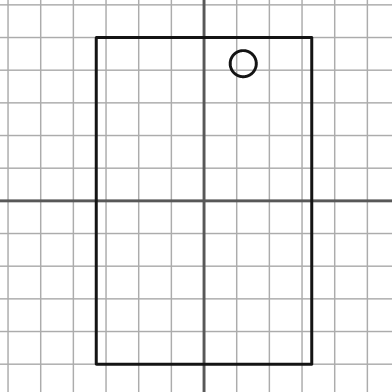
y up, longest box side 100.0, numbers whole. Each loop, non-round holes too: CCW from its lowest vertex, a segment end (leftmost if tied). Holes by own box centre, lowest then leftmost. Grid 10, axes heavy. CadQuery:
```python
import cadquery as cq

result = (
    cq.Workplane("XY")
    .moveTo(-33.0, -50.0)
    .lineTo(33.0, -50.0)
    .lineTo(33.0, 50.0)
    .lineTo(-33.0, 50.0)
    .close()
    .moveTo(12.0, 42.0)
    .circle(4.0)
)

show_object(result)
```